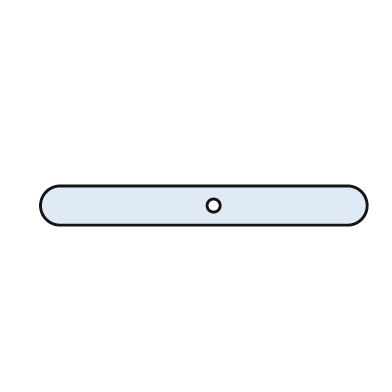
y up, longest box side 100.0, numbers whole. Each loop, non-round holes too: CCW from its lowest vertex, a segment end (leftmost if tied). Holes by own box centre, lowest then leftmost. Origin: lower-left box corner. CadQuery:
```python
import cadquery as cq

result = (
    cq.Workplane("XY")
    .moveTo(6.0, 0.0)
    .lineTo(94.0, 0.0)
    .threePointArc((100.0, 6.0), (94.0, 12.0))
    .lineTo(6.0, 12.0)
    .threePointArc((0.0, 6.0), (6.0, 0.0))
    .close()
    .moveTo(53.0, 6.0)
    .circle(2.0)
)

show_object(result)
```